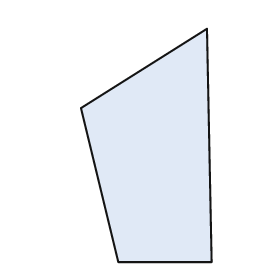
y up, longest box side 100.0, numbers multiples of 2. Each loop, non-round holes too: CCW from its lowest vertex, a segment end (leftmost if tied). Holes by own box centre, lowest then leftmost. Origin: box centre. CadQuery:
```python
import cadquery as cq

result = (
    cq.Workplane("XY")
    .moveTo(-12.0, -50.0)
    .lineTo(28.0, -50.0)
    .lineTo(26.0, 50.0)
    .lineTo(-28.0, 16.0)
    .close()
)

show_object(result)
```